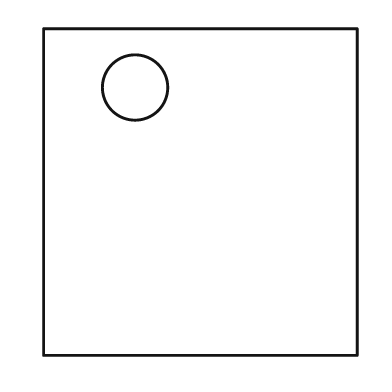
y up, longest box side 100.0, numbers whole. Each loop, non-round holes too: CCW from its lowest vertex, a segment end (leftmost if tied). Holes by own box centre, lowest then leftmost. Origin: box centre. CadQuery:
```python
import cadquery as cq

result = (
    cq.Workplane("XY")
    .moveTo(-48.0, -50.0)
    .lineTo(48.0, -50.0)
    .lineTo(48.0, 50.0)
    .lineTo(-48.0, 50.0)
    .close()
    .moveTo(-20.0, 32.0)
    .circle(10.0)
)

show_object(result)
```